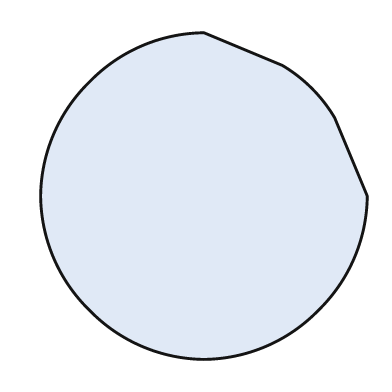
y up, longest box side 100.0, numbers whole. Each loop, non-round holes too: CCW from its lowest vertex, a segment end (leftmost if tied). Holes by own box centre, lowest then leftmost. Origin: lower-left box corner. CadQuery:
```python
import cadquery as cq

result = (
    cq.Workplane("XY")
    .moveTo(50.0, 0.0)
    .threePointArc((69.0, 4.0), (85.0, 15.0))
    .threePointArc((96.0, 31.0), (100.0, 50.0))
    .lineTo(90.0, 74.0)
    .threePointArc((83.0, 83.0), (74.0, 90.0))
    .lineTo(50.0, 100.0)
    .threePointArc((31.0, 96.0), (15.0, 85.0))
    .threePointArc((4.0, 69.0), (0.0, 50.0))
    .threePointArc((4.0, 31.0), (15.0, 15.0))
    .threePointArc((31.0, 4.0), (50.0, 0.0))
    .close()
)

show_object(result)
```